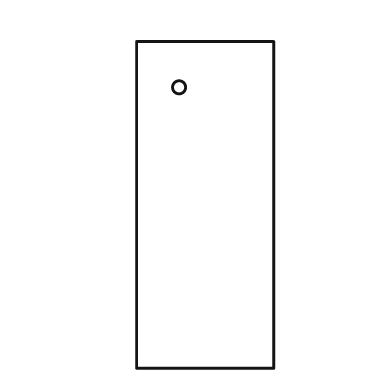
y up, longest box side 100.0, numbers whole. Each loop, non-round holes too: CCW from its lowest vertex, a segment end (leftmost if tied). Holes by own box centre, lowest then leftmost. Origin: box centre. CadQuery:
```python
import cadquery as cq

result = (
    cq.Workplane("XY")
    .moveTo(-21.0, -50.0)
    .lineTo(21.0, -50.0)
    .lineTo(21.0, 50.0)
    .lineTo(-21.0, 50.0)
    .close()
    .moveTo(-8.0, 36.0)
    .circle(2.0)
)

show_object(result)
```